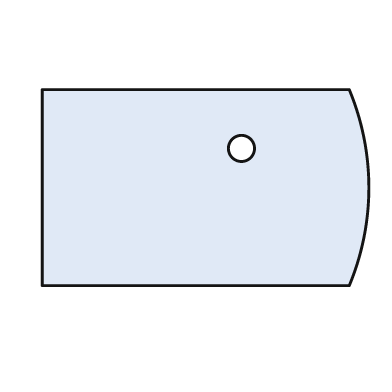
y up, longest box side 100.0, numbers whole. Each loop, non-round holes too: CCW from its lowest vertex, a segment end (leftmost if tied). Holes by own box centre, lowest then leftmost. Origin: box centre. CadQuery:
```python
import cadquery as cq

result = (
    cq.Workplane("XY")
    .moveTo(-50.0, -30.0)
    .lineTo(44.0, -30.0)
    .threePointArc((50.0, 0.0), (44.0, 30.0))
    .lineTo(-50.0, 30.0)
    .close()
    .moveTo(11.0, 12.0)
    .circle(4.0)
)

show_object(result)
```